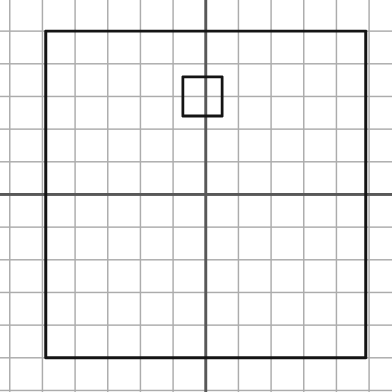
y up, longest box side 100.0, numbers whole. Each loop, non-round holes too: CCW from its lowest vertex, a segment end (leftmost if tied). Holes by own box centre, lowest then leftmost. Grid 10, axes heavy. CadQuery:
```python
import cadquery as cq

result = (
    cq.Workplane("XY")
    .moveTo(-49.0, -50.0)
    .lineTo(49.0, -50.0)
    .lineTo(49.0, 50.0)
    .lineTo(-49.0, 50.0)
    .close()
    .moveTo(-7.0, 24.0)
    .lineTo(5.0, 24.0)
    .lineTo(5.0, 36.0)
    .lineTo(-7.0, 36.0)
    .close()
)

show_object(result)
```